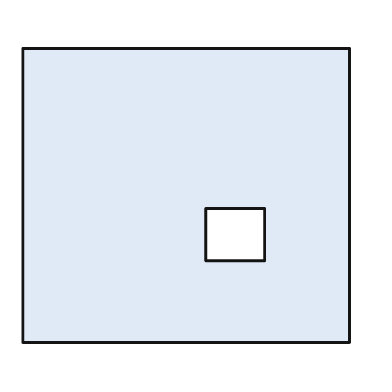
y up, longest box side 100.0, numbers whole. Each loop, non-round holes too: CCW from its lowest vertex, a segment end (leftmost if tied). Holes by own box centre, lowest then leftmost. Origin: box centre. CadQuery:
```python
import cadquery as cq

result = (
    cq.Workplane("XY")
    .moveTo(-50.0, -45.0)
    .lineTo(50.0, -45.0)
    .lineTo(50.0, 45.0)
    .lineTo(-50.0, 45.0)
    .close()
    .moveTo(6.0, -20.0)
    .lineTo(24.0, -20.0)
    .lineTo(24.0, -4.0)
    .lineTo(6.0, -4.0)
    .close()
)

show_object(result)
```